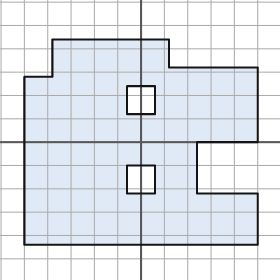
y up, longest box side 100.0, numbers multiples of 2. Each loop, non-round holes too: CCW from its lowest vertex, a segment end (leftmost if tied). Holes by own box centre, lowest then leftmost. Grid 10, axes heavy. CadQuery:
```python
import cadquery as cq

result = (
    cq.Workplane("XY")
    .moveTo(-50.0, -44.0)
    .lineTo(50.0, -44.0)
    .lineTo(50.0, -22.0)
    .lineTo(24.0, -22.0)
    .lineTo(24.0, 0.0)
    .lineTo(50.0, 0.0)
    .lineTo(50.0, 32.0)
    .lineTo(12.0, 32.0)
    .lineTo(12.0, 44.0)
    .lineTo(-38.0, 44.0)
    .lineTo(-38.0, 28.0)
    .lineTo(-50.0, 28.0)
    .close()
    .moveTo(-6.0, -22.0)
    .lineTo(6.0, -22.0)
    .lineTo(6.0, -10.0)
    .lineTo(-6.0, -10.0)
    .close()
    .moveTo(-6.0, 12.0)
    .lineTo(6.0, 12.0)
    .lineTo(6.0, 24.0)
    .lineTo(-6.0, 24.0)
    .close()
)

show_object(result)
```